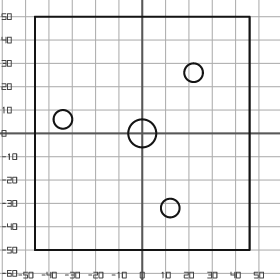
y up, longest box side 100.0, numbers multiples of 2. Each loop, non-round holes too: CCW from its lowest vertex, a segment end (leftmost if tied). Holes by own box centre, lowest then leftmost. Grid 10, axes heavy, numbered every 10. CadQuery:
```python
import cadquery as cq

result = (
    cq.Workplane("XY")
    .moveTo(-46.0, -50.0)
    .lineTo(46.0, -50.0)
    .lineTo(46.0, 50.0)
    .lineTo(-46.0, 50.0)
    .close()
    .moveTo(12.0, -32.0)
    .circle(4.0)
    .moveTo(0.0, 0.0)
    .circle(6.0)
    .moveTo(-34.0, 6.0)
    .circle(4.0)
    .moveTo(22.0, 26.0)
    .circle(4.0)
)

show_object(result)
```